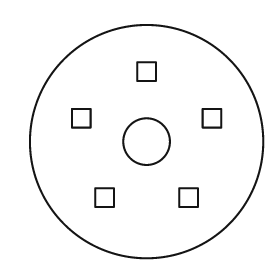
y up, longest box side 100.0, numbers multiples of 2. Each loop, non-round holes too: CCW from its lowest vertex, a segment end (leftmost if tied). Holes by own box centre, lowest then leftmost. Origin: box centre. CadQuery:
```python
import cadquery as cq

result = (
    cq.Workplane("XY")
    .moveTo(0.0, 0.0)
    .circle(50.0)
    .moveTo(-22.0, -28.0)
    .lineTo(-14.0, -28.0)
    .lineTo(-14.0, -20.0)
    .lineTo(-22.0, -20.0)
    .close()
    .moveTo(14.0, -28.0)
    .lineTo(22.0, -28.0)
    .lineTo(22.0, -20.0)
    .lineTo(14.0, -20.0)
    .close()
    .moveTo(0.0, 0.0)
    .circle(10.0)
    .moveTo(-32.0, 6.0)
    .lineTo(-24.0, 6.0)
    .lineTo(-24.0, 14.0)
    .lineTo(-32.0, 14.0)
    .close()
    .moveTo(24.0, 6.0)
    .lineTo(32.0, 6.0)
    .lineTo(32.0, 14.0)
    .lineTo(24.0, 14.0)
    .close()
    .moveTo(-4.0, 26.0)
    .lineTo(4.0, 26.0)
    .lineTo(4.0, 34.0)
    .lineTo(-4.0, 34.0)
    .close()
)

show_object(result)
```